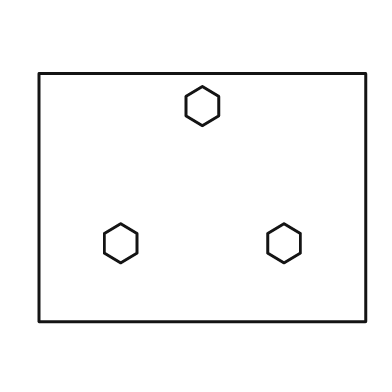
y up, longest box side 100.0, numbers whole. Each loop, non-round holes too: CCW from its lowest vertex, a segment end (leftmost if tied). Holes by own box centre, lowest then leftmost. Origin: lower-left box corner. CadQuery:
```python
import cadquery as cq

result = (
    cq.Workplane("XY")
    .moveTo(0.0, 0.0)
    .lineTo(100.0, 0.0)
    .lineTo(100.0, 76.0)
    .lineTo(0.0, 76.0)
    .close()
    .moveTo(25.0, 18.0)
    .lineTo(30.0, 21.0)
    .lineTo(30.0, 27.0)
    .lineTo(25.0, 30.0)
    .lineTo(20.0, 27.0)
    .lineTo(20.0, 21.0)
    .close()
    .moveTo(75.0, 18.0)
    .lineTo(80.0, 21.0)
    .lineTo(80.0, 27.0)
    .lineTo(75.0, 30.0)
    .lineTo(70.0, 27.0)
    .lineTo(70.0, 21.0)
    .close()
    .moveTo(50.0, 60.0)
    .lineTo(55.0, 63.0)
    .lineTo(55.0, 69.0)
    .lineTo(50.0, 72.0)
    .lineTo(45.0, 69.0)
    .lineTo(45.0, 63.0)
    .close()
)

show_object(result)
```